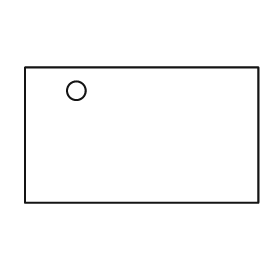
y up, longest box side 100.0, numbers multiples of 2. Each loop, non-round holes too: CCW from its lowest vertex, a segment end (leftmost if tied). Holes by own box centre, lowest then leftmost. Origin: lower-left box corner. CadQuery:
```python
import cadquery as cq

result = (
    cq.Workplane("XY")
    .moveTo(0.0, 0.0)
    .lineTo(100.0, 0.0)
    .lineTo(100.0, 58.0)
    .lineTo(0.0, 58.0)
    .close()
    .moveTo(22.0, 48.0)
    .circle(4.0)
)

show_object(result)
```